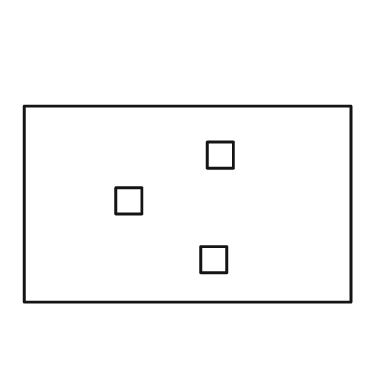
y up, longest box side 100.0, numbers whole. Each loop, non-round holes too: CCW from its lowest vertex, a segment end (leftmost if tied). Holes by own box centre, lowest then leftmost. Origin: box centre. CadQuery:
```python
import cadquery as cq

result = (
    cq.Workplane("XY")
    .moveTo(-50.0, -30.0)
    .lineTo(50.0, -30.0)
    .lineTo(50.0, 30.0)
    .lineTo(-50.0, 30.0)
    .close()
    .moveTo(4.0, -21.0)
    .lineTo(12.0, -21.0)
    .lineTo(12.0, -13.0)
    .lineTo(4.0, -13.0)
    .close()
    .moveTo(-22.0, -3.0)
    .lineTo(-14.0, -3.0)
    .lineTo(-14.0, 5.0)
    .lineTo(-22.0, 5.0)
    .close()
    .moveTo(6.0, 11.0)
    .lineTo(14.0, 11.0)
    .lineTo(14.0, 19.0)
    .lineTo(6.0, 19.0)
    .close()
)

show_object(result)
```